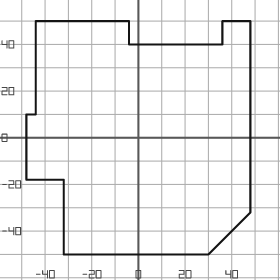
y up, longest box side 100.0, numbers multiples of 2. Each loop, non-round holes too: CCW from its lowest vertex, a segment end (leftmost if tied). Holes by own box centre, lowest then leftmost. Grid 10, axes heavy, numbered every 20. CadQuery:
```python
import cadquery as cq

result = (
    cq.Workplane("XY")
    .moveTo(-32.0, -50.0)
    .lineTo(30.0, -50.0)
    .lineTo(48.0, -32.0)
    .lineTo(48.0, 50.0)
    .lineTo(36.0, 50.0)
    .lineTo(36.0, 40.0)
    .lineTo(-4.0, 40.0)
    .lineTo(-4.0, 50.0)
    .lineTo(-44.0, 50.0)
    .lineTo(-44.0, 10.0)
    .lineTo(-48.0, 10.0)
    .lineTo(-48.0, -18.0)
    .lineTo(-32.0, -18.0)
    .close()
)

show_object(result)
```